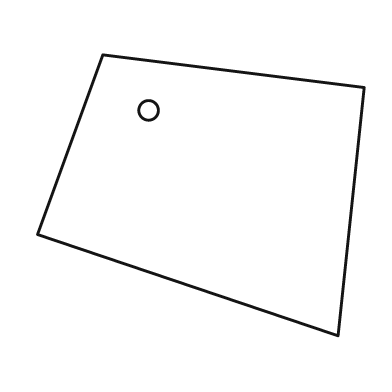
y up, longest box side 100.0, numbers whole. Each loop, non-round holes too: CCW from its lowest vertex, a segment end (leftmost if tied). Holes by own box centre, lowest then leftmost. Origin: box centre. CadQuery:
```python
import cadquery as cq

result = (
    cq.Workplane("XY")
    .moveTo(42.0, -43.0)
    .lineTo(50.0, 33.0)
    .lineTo(-30.0, 43.0)
    .lineTo(-50.0, -12.0)
    .close()
    .moveTo(-16.0, 26.0)
    .circle(3.0)
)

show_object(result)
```